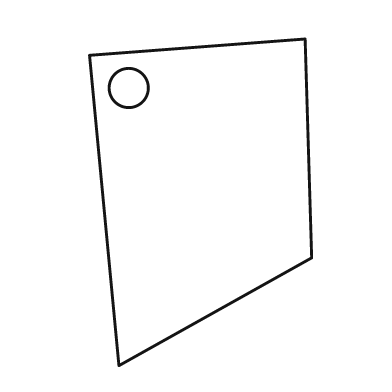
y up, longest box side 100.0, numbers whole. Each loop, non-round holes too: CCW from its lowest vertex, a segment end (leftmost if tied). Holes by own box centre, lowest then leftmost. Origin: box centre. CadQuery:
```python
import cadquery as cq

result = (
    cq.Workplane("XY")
    .moveTo(-25.0, -50.0)
    .lineTo(34.0, -17.0)
    .lineTo(32.0, 50.0)
    .lineTo(-34.0, 45.0)
    .close()
    .moveTo(-22.0, 35.0)
    .circle(6.0)
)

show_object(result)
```